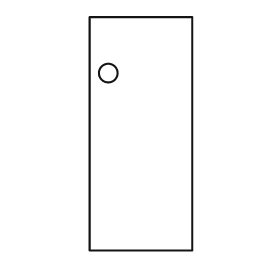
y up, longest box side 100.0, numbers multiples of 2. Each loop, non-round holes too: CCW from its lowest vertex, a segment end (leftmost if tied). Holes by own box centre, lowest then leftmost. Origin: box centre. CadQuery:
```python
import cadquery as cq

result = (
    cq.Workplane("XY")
    .moveTo(-22.0, -50.0)
    .lineTo(22.0, -50.0)
    .lineTo(22.0, 50.0)
    .lineTo(-22.0, 50.0)
    .close()
    .moveTo(-14.0, 26.0)
    .circle(4.0)
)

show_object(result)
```